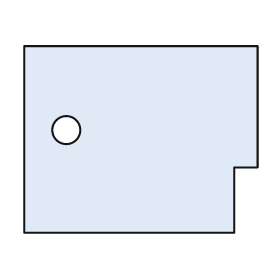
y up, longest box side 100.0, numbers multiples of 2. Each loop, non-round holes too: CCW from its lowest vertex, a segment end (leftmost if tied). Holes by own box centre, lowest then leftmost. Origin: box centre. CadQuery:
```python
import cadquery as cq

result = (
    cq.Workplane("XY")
    .moveTo(-50.0, -40.0)
    .lineTo(40.0, -40.0)
    .lineTo(40.0, -12.0)
    .lineTo(50.0, -12.0)
    .lineTo(50.0, 40.0)
    .lineTo(-50.0, 40.0)
    .close()
    .moveTo(-32.0, 4.0)
    .circle(6.0)
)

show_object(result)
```